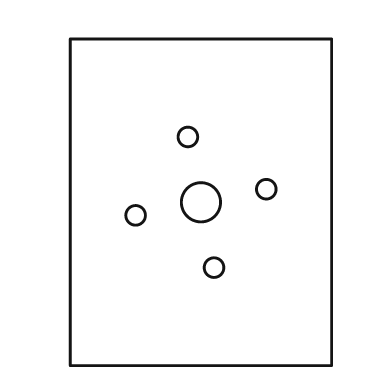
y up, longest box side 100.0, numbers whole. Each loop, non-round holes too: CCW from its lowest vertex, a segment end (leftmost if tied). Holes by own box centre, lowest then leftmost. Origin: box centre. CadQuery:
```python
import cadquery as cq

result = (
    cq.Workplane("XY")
    .moveTo(-40.0, -50.0)
    .lineTo(40.0, -50.0)
    .lineTo(40.0, 50.0)
    .lineTo(-40.0, 50.0)
    .close()
    .moveTo(4.0, -20.0)
    .circle(3.0)
    .moveTo(-20.0, -4.0)
    .circle(3.0)
    .moveTo(0.0, 0.0)
    .circle(6.0)
    .moveTo(20.0, 4.0)
    .circle(3.0)
    .moveTo(-4.0, 20.0)
    .circle(3.0)
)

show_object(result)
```